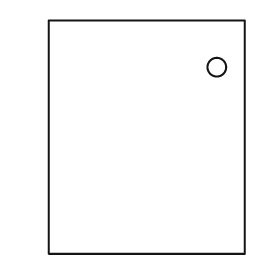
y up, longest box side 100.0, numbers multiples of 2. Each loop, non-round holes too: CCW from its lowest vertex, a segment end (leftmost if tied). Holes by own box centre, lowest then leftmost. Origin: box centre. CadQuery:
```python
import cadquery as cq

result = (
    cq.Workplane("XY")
    .moveTo(-42.0, -50.0)
    .lineTo(42.0, -50.0)
    .lineTo(42.0, 50.0)
    .lineTo(-42.0, 50.0)
    .close()
    .moveTo(30.0, 30.0)
    .circle(4.0)
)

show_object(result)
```